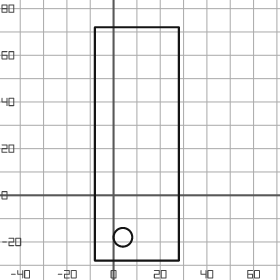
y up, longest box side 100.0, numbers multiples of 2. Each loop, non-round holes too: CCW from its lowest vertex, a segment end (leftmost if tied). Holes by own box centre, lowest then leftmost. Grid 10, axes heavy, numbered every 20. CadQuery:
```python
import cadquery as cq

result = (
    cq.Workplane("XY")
    .moveTo(-8.0, -28.0)
    .lineTo(28.0, -28.0)
    .lineTo(28.0, 72.0)
    .lineTo(-8.0, 72.0)
    .close()
    .moveTo(4.0, -18.0)
    .circle(4.0)
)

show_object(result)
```